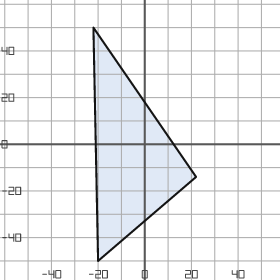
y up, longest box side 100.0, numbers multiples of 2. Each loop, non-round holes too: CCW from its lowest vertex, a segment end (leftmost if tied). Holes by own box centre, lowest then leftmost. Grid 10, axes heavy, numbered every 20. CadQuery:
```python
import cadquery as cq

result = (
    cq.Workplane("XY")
    .moveTo(-20.0, -50.0)
    .lineTo(22.0, -14.0)
    .lineTo(-22.0, 50.0)
    .close()
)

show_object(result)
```